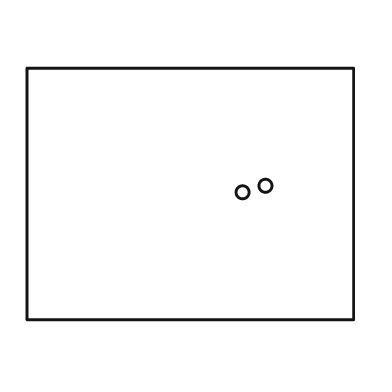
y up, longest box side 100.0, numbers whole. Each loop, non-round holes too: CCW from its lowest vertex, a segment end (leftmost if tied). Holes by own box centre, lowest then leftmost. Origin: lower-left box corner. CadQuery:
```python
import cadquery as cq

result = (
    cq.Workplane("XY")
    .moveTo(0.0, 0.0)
    .lineTo(100.0, 0.0)
    .lineTo(100.0, 77.0)
    .lineTo(0.0, 77.0)
    .close()
    .moveTo(66.0, 39.0)
    .circle(2.0)
    .moveTo(73.0, 41.0)
    .circle(2.0)
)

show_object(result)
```